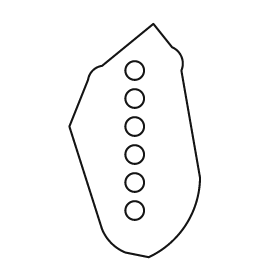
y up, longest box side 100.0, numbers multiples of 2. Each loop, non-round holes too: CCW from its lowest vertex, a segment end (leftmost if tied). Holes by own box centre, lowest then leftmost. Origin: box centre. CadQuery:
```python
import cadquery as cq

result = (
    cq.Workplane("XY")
    .moveTo(6.0, -50.0)
    .threePointArc((22.0, -36.0), (28.0, -16.0))
    .lineTo(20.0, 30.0)
    .threePointArc((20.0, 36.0), (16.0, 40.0))
    .lineTo(8.0, 50.0)
    .lineTo(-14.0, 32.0)
    .threePointArc((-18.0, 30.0), (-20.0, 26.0))
    .lineTo(-28.0, 6.0)
    .lineTo(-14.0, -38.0)
    .threePointArc((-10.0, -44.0), (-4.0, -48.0))
    .close()
    .moveTo(0.0, -30.0)
    .circle(4.0)
    .moveTo(0.0, -18.0)
    .circle(4.0)
    .moveTo(0.0, -6.0)
    .circle(4.0)
    .moveTo(0.0, 6.0)
    .circle(4.0)
    .moveTo(0.0, 18.0)
    .circle(4.0)
    .moveTo(0.0, 30.0)
    .circle(4.0)
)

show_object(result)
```